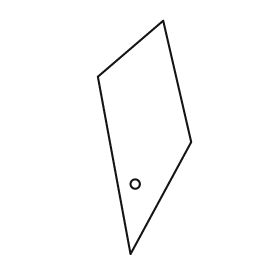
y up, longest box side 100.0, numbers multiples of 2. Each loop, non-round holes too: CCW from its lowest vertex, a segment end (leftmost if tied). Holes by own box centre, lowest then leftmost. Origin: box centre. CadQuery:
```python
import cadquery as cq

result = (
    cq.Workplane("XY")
    .moveTo(-6.0, -50.0)
    .lineTo(20.0, -2.0)
    .lineTo(8.0, 50.0)
    .lineTo(-20.0, 26.0)
    .close()
    .moveTo(-4.0, -20.0)
    .circle(2.0)
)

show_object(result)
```